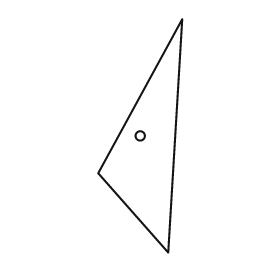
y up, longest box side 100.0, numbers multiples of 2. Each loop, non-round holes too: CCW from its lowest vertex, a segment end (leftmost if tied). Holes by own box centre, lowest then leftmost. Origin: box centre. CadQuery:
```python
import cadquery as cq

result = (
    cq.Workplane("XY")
    .moveTo(12.0, -50.0)
    .lineTo(18.0, 50.0)
    .lineTo(-18.0, -16.0)
    .close()
    .moveTo(0.0, 0.0)
    .circle(2.0)
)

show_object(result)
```